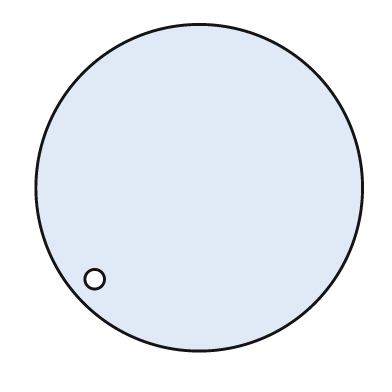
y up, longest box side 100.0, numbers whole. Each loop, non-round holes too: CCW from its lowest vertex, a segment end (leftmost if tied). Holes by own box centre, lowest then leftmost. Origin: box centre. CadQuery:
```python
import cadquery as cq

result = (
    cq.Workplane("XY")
    .moveTo(0.0, 0.0)
    .circle(50.0)
    .moveTo(-32.0, -28.0)
    .circle(3.0)
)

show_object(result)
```